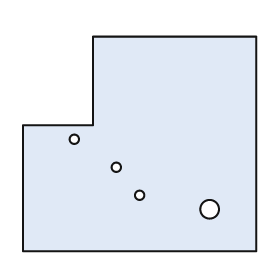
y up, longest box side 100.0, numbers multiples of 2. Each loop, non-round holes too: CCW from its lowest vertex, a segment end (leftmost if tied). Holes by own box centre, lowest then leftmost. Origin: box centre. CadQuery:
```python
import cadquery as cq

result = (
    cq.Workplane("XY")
    .moveTo(-50.0, -46.0)
    .lineTo(50.0, -46.0)
    .lineTo(50.0, 46.0)
    .lineTo(-20.0, 46.0)
    .lineTo(-20.0, 8.0)
    .lineTo(-50.0, 8.0)
    .close()
    .moveTo(30.0, -28.0)
    .circle(4.0)
    .moveTo(0.0, -22.0)
    .circle(2.0)
    .moveTo(-10.0, -10.0)
    .circle(2.0)
    .moveTo(-28.0, 2.0)
    .circle(2.0)
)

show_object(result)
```